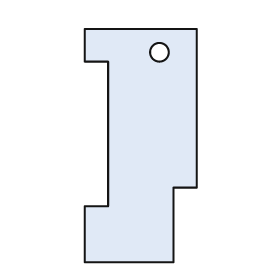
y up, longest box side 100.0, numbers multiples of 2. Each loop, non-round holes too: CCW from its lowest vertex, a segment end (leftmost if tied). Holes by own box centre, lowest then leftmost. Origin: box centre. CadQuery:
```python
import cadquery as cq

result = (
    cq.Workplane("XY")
    .moveTo(-24.0, -50.0)
    .lineTo(14.0, -50.0)
    .lineTo(14.0, -18.0)
    .lineTo(24.0, -18.0)
    .lineTo(24.0, 50.0)
    .lineTo(-24.0, 50.0)
    .lineTo(-24.0, 36.0)
    .lineTo(-14.0, 36.0)
    .lineTo(-14.0, -26.0)
    .lineTo(-24.0, -26.0)
    .close()
    .moveTo(8.0, 40.0)
    .circle(4.0)
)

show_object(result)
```